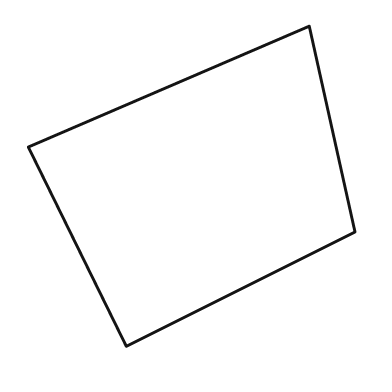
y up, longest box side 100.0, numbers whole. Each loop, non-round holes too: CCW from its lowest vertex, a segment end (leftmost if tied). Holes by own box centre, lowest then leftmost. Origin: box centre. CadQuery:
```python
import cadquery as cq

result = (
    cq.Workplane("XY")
    .moveTo(-20.0, -49.0)
    .lineTo(50.0, -14.0)
    .lineTo(36.0, 49.0)
    .lineTo(-50.0, 12.0)
    .close()
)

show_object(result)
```